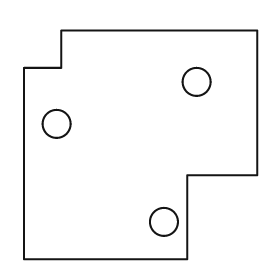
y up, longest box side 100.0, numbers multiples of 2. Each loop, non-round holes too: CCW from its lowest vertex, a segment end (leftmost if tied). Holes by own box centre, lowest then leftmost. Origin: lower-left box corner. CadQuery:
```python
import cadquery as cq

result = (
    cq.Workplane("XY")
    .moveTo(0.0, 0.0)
    .lineTo(70.0, 0.0)
    .lineTo(70.0, 36.0)
    .lineTo(100.0, 36.0)
    .lineTo(100.0, 98.0)
    .lineTo(16.0, 98.0)
    .lineTo(16.0, 82.0)
    .lineTo(0.0, 82.0)
    .close()
    .moveTo(60.0, 16.0)
    .circle(6.0)
    .moveTo(14.0, 58.0)
    .circle(6.0)
    .moveTo(74.0, 76.0)
    .circle(6.0)
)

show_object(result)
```